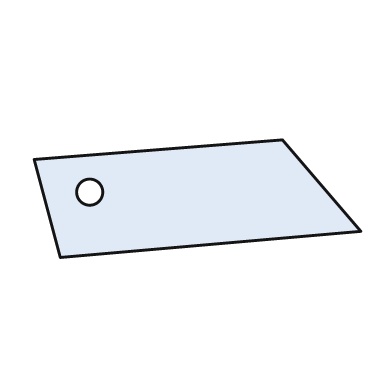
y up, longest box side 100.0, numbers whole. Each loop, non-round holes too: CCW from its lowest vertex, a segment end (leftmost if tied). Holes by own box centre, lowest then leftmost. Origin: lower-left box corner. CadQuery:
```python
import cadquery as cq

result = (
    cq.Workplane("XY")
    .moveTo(8.0, 0.0)
    .lineTo(100.0, 8.0)
    .lineTo(76.0, 36.0)
    .lineTo(0.0, 30.0)
    .close()
    .moveTo(17.0, 20.0)
    .circle(4.0)
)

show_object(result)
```